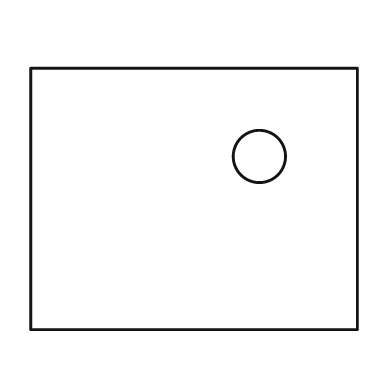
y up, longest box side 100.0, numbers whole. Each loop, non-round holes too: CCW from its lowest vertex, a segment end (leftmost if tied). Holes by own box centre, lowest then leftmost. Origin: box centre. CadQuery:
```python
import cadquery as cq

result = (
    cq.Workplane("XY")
    .moveTo(-50.0, -40.0)
    .lineTo(50.0, -40.0)
    .lineTo(50.0, 40.0)
    .lineTo(-50.0, 40.0)
    .close()
    .moveTo(20.0, 13.0)
    .circle(8.0)
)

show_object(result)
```